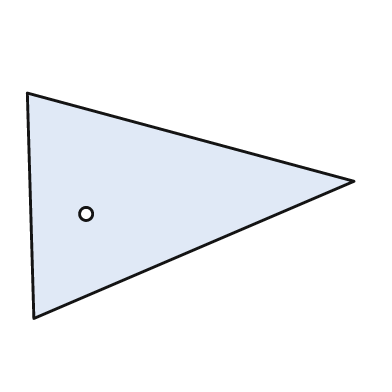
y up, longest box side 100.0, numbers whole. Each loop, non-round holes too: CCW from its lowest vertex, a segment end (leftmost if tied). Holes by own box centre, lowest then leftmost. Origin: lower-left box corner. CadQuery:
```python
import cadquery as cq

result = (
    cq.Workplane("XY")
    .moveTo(2.0, 0.0)
    .lineTo(100.0, 42.0)
    .lineTo(0.0, 69.0)
    .close()
    .moveTo(18.0, 32.0)
    .circle(2.0)
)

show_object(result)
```